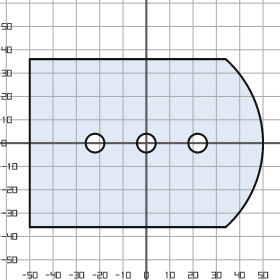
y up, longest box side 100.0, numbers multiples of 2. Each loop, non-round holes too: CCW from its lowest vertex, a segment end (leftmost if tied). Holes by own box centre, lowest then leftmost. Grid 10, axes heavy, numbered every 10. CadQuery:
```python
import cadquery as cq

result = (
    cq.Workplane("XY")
    .moveTo(-50.0, -36.0)
    .lineTo(34.0, -36.0)
    .threePointArc((50.0, 0.0), (34.0, 36.0))
    .lineTo(-50.0, 36.0)
    .close()
    .moveTo(-22.0, 0.0)
    .circle(4.0)
    .moveTo(0.0, 0.0)
    .circle(4.0)
    .moveTo(22.0, 0.0)
    .circle(4.0)
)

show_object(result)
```